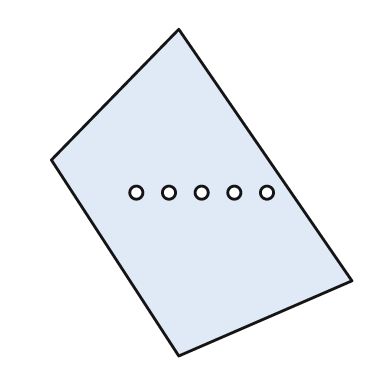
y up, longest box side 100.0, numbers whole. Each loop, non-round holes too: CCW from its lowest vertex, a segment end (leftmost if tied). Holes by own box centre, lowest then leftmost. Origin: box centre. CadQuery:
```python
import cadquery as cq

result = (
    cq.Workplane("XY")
    .moveTo(-7.0, -50.0)
    .lineTo(46.0, -27.0)
    .lineTo(-7.0, 50.0)
    .lineTo(-46.0, 10.0)
    .close()
    .moveTo(-20.0, 0.0)
    .circle(2.0)
    .moveTo(-10.0, 0.0)
    .circle(2.0)
    .moveTo(0.0, 0.0)
    .circle(2.0)
    .moveTo(10.0, 0.0)
    .circle(2.0)
    .moveTo(20.0, 0.0)
    .circle(2.0)
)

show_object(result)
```